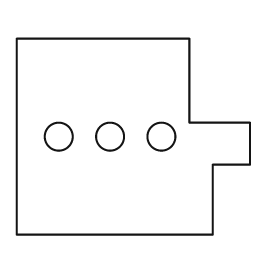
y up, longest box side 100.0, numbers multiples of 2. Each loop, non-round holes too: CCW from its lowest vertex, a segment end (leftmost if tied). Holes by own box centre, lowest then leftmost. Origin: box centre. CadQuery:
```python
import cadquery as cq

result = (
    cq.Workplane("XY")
    .moveTo(-50.0, -42.0)
    .lineTo(34.0, -42.0)
    .lineTo(34.0, -12.0)
    .lineTo(50.0, -12.0)
    .lineTo(50.0, 6.0)
    .lineTo(24.0, 6.0)
    .lineTo(24.0, 42.0)
    .lineTo(-50.0, 42.0)
    .close()
    .moveTo(-32.0, 0.0)
    .circle(6.0)
    .moveTo(-10.0, 0.0)
    .circle(6.0)
    .moveTo(12.0, 0.0)
    .circle(6.0)
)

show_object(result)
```